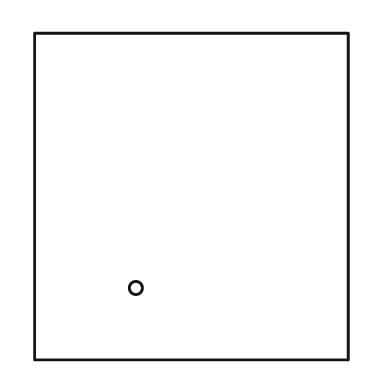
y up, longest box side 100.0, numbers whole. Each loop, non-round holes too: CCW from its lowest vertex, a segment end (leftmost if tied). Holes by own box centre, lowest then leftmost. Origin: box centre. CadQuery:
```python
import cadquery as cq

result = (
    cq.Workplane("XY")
    .moveTo(-48.0, -50.0)
    .lineTo(48.0, -50.0)
    .lineTo(48.0, 50.0)
    .lineTo(-48.0, 50.0)
    .close()
    .moveTo(-17.0, -28.0)
    .circle(2.0)
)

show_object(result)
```